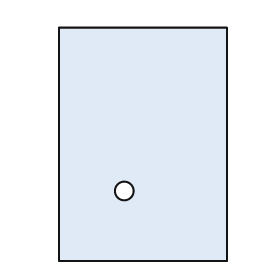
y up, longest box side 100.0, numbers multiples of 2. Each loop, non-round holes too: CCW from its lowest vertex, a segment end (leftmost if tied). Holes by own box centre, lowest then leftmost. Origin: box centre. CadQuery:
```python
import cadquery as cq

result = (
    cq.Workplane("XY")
    .moveTo(-36.0, -50.0)
    .lineTo(36.0, -50.0)
    .lineTo(36.0, 50.0)
    .lineTo(-36.0, 50.0)
    .close()
    .moveTo(-8.0, -20.0)
    .circle(4.0)
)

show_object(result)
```